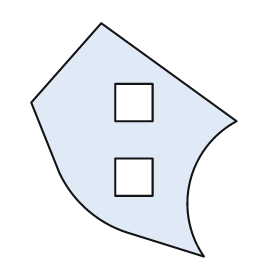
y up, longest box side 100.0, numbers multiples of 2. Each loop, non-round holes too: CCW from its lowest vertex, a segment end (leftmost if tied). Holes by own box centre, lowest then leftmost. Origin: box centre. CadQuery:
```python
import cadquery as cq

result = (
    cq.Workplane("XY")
    .moveTo(30.0, -50.0)
    .threePointArc((24.0, -18.0), (44.0, 8.0))
    .lineTo(-14.0, 50.0)
    .lineTo(-44.0, 16.0)
    .lineTo(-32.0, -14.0)
    .threePointArc((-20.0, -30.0), (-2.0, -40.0))
    .close()
    .moveTo(-8.0, -24.0)
    .lineTo(8.0, -24.0)
    .lineTo(8.0, -8.0)
    .lineTo(-8.0, -8.0)
    .close()
    .moveTo(-8.0, 8.0)
    .lineTo(8.0, 8.0)
    .lineTo(8.0, 24.0)
    .lineTo(-8.0, 24.0)
    .close()
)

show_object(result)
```